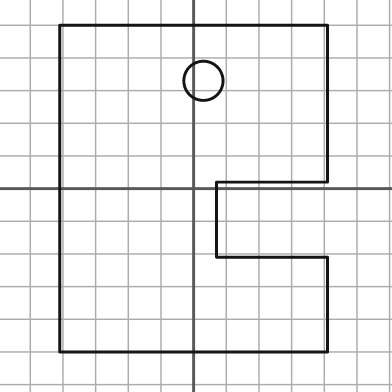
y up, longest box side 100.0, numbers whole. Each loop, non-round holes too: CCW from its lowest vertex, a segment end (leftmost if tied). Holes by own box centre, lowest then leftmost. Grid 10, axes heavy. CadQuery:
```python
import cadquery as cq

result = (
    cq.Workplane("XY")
    .moveTo(-41.0, -50.0)
    .lineTo(41.0, -50.0)
    .lineTo(41.0, -21.0)
    .lineTo(7.0, -21.0)
    .lineTo(7.0, 2.0)
    .lineTo(41.0, 2.0)
    .lineTo(41.0, 50.0)
    .lineTo(-41.0, 50.0)
    .close()
    .moveTo(3.0, 33.0)
    .circle(6.0)
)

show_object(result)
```